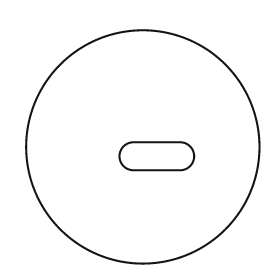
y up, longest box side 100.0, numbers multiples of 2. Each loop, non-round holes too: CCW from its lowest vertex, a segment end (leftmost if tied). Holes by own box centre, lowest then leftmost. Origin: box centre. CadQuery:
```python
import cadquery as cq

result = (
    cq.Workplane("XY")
    .moveTo(0.0, 0.0)
    .circle(50.0)
    .moveTo(-4.0, -10.0)
    .lineTo(16.0, -10.0)
    .threePointArc((22.0, -4.0), (16.0, 2.0))
    .lineTo(-4.0, 2.0)
    .threePointArc((-10.0, -4.0), (-4.0, -10.0))
    .close()
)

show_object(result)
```